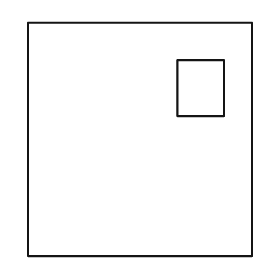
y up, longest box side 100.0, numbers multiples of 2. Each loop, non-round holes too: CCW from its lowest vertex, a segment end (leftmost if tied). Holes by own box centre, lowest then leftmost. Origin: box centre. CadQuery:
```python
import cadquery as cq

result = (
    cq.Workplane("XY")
    .moveTo(-48.0, -50.0)
    .lineTo(48.0, -50.0)
    .lineTo(48.0, 50.0)
    .lineTo(-48.0, 50.0)
    .close()
    .moveTo(16.0, 10.0)
    .lineTo(36.0, 10.0)
    .lineTo(36.0, 34.0)
    .lineTo(16.0, 34.0)
    .close()
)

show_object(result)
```